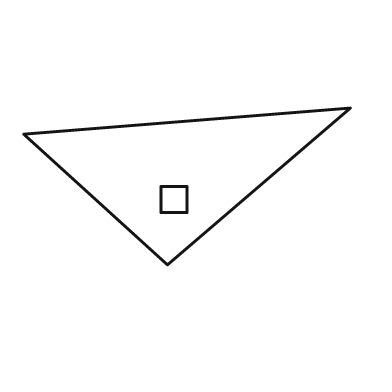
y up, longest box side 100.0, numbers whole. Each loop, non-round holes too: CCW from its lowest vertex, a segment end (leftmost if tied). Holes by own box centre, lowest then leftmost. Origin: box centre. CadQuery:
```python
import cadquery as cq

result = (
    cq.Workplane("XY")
    .moveTo(-6.0, -24.0)
    .lineTo(50.0, 24.0)
    .lineTo(-50.0, 16.0)
    .close()
    .moveTo(-8.0, -8.0)
    .lineTo(0.0, -8.0)
    .lineTo(0.0, 0.0)
    .lineTo(-8.0, 0.0)
    .close()
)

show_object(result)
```